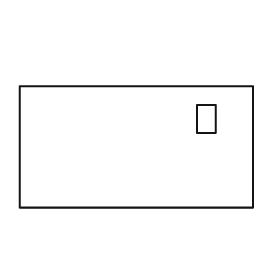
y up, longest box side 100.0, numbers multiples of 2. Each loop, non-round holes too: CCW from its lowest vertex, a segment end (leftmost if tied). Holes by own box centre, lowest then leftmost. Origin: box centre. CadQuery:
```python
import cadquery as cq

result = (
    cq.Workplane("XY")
    .moveTo(-50.0, -26.0)
    .lineTo(50.0, -26.0)
    .lineTo(50.0, 26.0)
    .lineTo(-50.0, 26.0)
    .close()
    .moveTo(26.0, 6.0)
    .lineTo(34.0, 6.0)
    .lineTo(34.0, 18.0)
    .lineTo(26.0, 18.0)
    .close()
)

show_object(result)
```